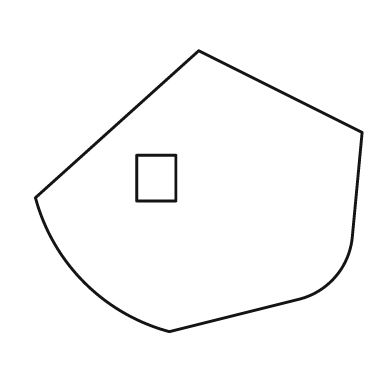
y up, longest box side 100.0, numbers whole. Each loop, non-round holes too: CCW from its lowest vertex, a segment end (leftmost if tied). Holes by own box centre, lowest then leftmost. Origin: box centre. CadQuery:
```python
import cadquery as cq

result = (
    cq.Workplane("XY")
    .moveTo(-9.0, -43.0)
    .lineTo(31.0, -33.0)
    .threePointArc((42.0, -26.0), (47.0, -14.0))
    .lineTo(50.0, 18.0)
    .lineTo(0.0, 43.0)
    .lineTo(-50.0, -2.0)
    .threePointArc((-35.0, -28.0), (-9.0, -43.0))
    .close()
    .moveTo(-19.0, -3.0)
    .lineTo(-7.0, -3.0)
    .lineTo(-7.0, 11.0)
    .lineTo(-19.0, 11.0)
    .close()
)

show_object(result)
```